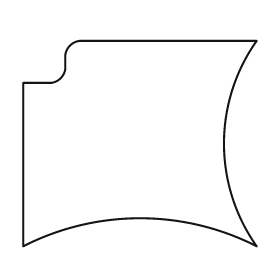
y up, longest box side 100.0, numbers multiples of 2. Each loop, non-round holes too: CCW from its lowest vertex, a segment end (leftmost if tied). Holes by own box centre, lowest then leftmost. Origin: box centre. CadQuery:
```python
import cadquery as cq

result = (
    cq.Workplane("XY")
    .moveTo(-50.0, -44.0)
    .threePointArc((0.0, -32.0), (50.0, -44.0))
    .threePointArc((36.0, 0.0), (50.0, 44.0))
    .lineTo(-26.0, 44.0)
    .threePointArc((-30.0, 42.0), (-32.0, 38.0))
    .lineTo(-32.0, 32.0)
    .threePointArc((-34.0, 28.0), (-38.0, 26.0))
    .lineTo(-50.0, 26.0)
    .close()
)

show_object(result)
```